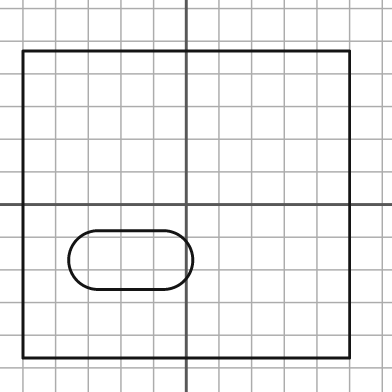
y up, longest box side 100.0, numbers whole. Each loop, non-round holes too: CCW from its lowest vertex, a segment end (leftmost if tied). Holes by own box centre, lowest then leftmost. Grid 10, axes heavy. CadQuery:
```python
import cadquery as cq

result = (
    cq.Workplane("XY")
    .moveTo(-50.0, -47.0)
    .lineTo(50.0, -47.0)
    .lineTo(50.0, 47.0)
    .lineTo(-50.0, 47.0)
    .close()
    .moveTo(-27.0, -26.0)
    .lineTo(-7.0, -26.0)
    .threePointArc((2.0, -17.0), (-7.0, -8.0))
    .lineTo(-27.0, -8.0)
    .threePointArc((-36.0, -17.0), (-27.0, -26.0))
    .close()
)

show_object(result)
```